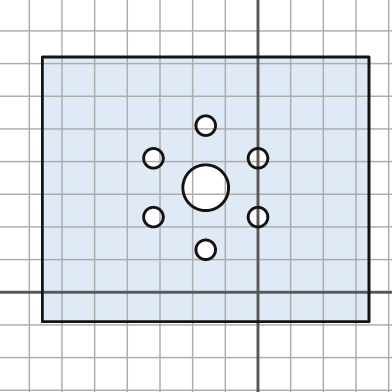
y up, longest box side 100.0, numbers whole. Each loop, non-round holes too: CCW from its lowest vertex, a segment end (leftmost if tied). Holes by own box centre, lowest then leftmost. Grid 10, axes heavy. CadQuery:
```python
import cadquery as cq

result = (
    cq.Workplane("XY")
    .moveTo(-66.0, -9.0)
    .lineTo(34.0, -9.0)
    .lineTo(34.0, 72.0)
    .lineTo(-66.0, 72.0)
    .close()
    .moveTo(-16.0, 13.0)
    .circle(3.0)
    .moveTo(-32.0, 23.0)
    .circle(3.0)
    .moveTo(0.0, 23.0)
    .circle(3.0)
    .moveTo(-16.0, 32.0)
    .circle(7.0)
    .moveTo(-32.0, 41.0)
    .circle(3.0)
    .moveTo(0.0, 41.0)
    .circle(3.0)
    .moveTo(-16.0, 51.0)
    .circle(3.0)
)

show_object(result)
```